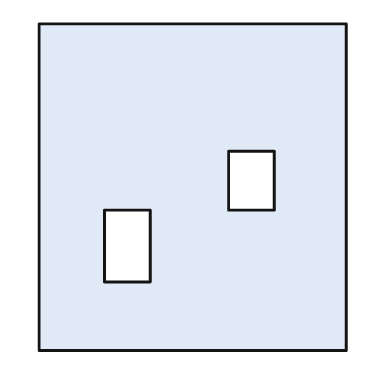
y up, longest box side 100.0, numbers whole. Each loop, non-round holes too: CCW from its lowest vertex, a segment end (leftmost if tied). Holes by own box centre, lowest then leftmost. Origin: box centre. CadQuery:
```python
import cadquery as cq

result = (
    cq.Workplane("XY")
    .moveTo(-47.0, -50.0)
    .lineTo(47.0, -50.0)
    .lineTo(47.0, 50.0)
    .lineTo(-47.0, 50.0)
    .close()
    .moveTo(-27.0, -29.0)
    .lineTo(-13.0, -29.0)
    .lineTo(-13.0, -7.0)
    .lineTo(-27.0, -7.0)
    .close()
    .moveTo(11.0, -7.0)
    .lineTo(25.0, -7.0)
    .lineTo(25.0, 11.0)
    .lineTo(11.0, 11.0)
    .close()
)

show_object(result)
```